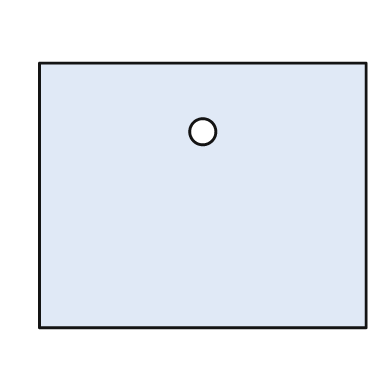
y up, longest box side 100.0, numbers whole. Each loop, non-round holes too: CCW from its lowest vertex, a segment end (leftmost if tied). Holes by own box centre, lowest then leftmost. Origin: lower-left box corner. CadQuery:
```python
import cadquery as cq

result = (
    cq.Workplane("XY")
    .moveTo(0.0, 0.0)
    .lineTo(100.0, 0.0)
    .lineTo(100.0, 81.0)
    .lineTo(0.0, 81.0)
    .close()
    .moveTo(50.0, 60.0)
    .circle(4.0)
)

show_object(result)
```